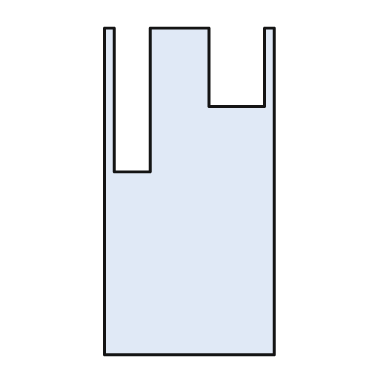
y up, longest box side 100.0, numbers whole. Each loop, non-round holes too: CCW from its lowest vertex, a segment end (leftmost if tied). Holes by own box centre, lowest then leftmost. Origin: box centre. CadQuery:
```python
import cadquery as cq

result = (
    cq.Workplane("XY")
    .moveTo(-26.0, -50.0)
    .lineTo(26.0, -50.0)
    .lineTo(26.0, 50.0)
    .lineTo(23.0, 50.0)
    .lineTo(23.0, 26.0)
    .lineTo(6.0, 26.0)
    .lineTo(6.0, 50.0)
    .lineTo(-12.0, 50.0)
    .lineTo(-12.0, 6.0)
    .lineTo(-23.0, 6.0)
    .lineTo(-23.0, 50.0)
    .lineTo(-26.0, 50.0)
    .close()
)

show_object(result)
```